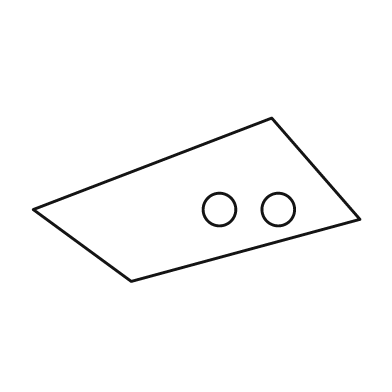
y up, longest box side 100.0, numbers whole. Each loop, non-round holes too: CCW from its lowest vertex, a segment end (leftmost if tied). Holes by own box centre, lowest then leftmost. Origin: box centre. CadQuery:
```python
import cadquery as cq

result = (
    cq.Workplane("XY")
    .moveTo(-20.0, -25.0)
    .lineTo(50.0, -6.0)
    .lineTo(23.0, 25.0)
    .lineTo(-50.0, -3.0)
    .close()
    .moveTo(7.0, -3.0)
    .circle(5.0)
    .moveTo(25.0, -3.0)
    .circle(5.0)
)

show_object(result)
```